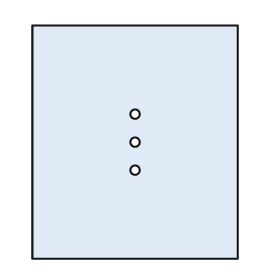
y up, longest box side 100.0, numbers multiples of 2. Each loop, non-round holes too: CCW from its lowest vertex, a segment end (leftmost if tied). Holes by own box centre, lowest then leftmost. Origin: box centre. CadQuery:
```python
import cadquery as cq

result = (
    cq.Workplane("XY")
    .moveTo(-44.0, -50.0)
    .lineTo(44.0, -50.0)
    .lineTo(44.0, 50.0)
    .lineTo(-44.0, 50.0)
    .close()
    .moveTo(0.0, -12.0)
    .circle(2.0)
    .moveTo(0.0, 0.0)
    .circle(2.0)
    .moveTo(0.0, 12.0)
    .circle(2.0)
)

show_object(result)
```